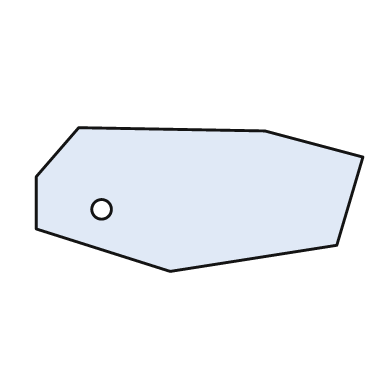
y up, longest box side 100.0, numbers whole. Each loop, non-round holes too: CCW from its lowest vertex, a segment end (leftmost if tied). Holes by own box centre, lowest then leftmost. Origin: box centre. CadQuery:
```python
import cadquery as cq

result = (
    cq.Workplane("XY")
    .moveTo(-9.0, -22.0)
    .lineTo(42.0, -14.0)
    .lineTo(50.0, 13.0)
    .lineTo(20.0, 21.0)
    .lineTo(-37.0, 22.0)
    .lineTo(-50.0, 7.0)
    .lineTo(-50.0, -9.0)
    .close()
    .moveTo(-30.0, -3.0)
    .circle(3.0)
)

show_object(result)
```